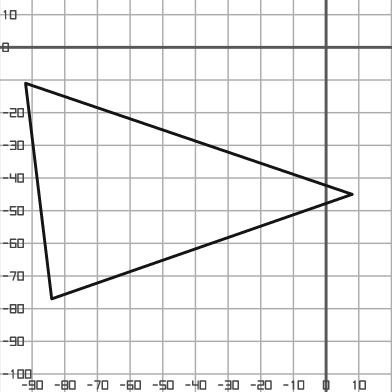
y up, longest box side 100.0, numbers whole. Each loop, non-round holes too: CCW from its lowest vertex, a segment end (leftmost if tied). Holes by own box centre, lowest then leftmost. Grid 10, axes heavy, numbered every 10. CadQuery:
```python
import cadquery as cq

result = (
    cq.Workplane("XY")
    .moveTo(-84.0, -77.0)
    .lineTo(8.0, -45.0)
    .lineTo(-92.0, -11.0)
    .close()
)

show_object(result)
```